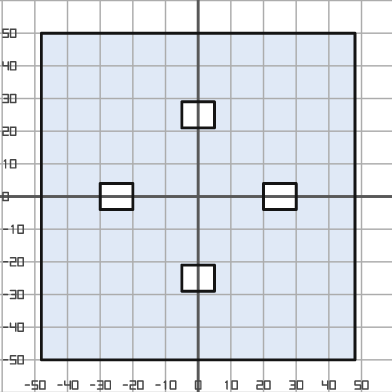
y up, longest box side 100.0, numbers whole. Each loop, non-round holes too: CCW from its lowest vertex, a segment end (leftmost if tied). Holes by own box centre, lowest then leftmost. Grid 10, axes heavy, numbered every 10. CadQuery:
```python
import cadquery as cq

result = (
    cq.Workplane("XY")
    .moveTo(-48.0, -50.0)
    .lineTo(48.0, -50.0)
    .lineTo(48.0, 50.0)
    .lineTo(-48.0, 50.0)
    .close()
    .moveTo(-5.0, -29.0)
    .lineTo(5.0, -29.0)
    .lineTo(5.0, -21.0)
    .lineTo(-5.0, -21.0)
    .close()
    .moveTo(-30.0, -4.0)
    .lineTo(-20.0, -4.0)
    .lineTo(-20.0, 4.0)
    .lineTo(-30.0, 4.0)
    .close()
    .moveTo(20.0, -4.0)
    .lineTo(30.0, -4.0)
    .lineTo(30.0, 4.0)
    .lineTo(20.0, 4.0)
    .close()
    .moveTo(-5.0, 21.0)
    .lineTo(5.0, 21.0)
    .lineTo(5.0, 29.0)
    .lineTo(-5.0, 29.0)
    .close()
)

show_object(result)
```